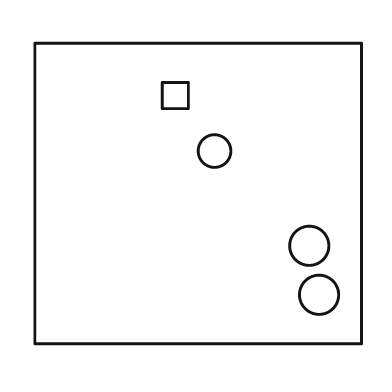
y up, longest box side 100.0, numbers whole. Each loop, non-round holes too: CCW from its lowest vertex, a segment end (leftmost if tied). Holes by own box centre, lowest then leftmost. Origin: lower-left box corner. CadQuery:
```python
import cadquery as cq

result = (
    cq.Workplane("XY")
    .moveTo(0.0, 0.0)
    .lineTo(100.0, 0.0)
    .lineTo(100.0, 92.0)
    .lineTo(0.0, 92.0)
    .close()
    .moveTo(87.0, 15.0)
    .circle(6.0)
    .moveTo(84.0, 30.0)
    .circle(6.0)
    .moveTo(55.0, 59.0)
    .circle(5.0)
    .moveTo(39.0, 72.0)
    .lineTo(47.0, 72.0)
    .lineTo(47.0, 80.0)
    .lineTo(39.0, 80.0)
    .close()
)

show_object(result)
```